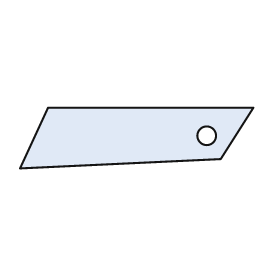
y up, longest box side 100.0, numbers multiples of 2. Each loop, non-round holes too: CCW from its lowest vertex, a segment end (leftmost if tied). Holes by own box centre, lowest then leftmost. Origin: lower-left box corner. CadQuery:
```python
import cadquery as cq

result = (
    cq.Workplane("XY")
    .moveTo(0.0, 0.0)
    .lineTo(86.0, 4.0)
    .lineTo(100.0, 26.0)
    .lineTo(12.0, 26.0)
    .close()
    .moveTo(80.0, 14.0)
    .circle(4.0)
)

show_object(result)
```